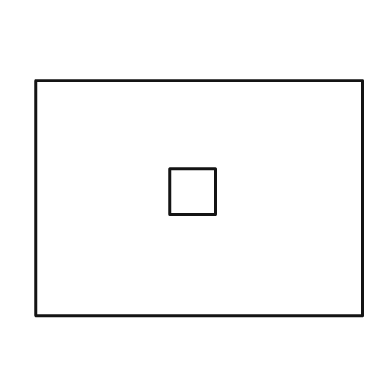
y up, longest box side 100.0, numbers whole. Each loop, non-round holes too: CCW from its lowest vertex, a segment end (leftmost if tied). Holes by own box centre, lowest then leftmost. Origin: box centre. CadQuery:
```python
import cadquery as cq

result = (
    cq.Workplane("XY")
    .moveTo(-50.0, -36.0)
    .lineTo(50.0, -36.0)
    .lineTo(50.0, 36.0)
    .lineTo(-50.0, 36.0)
    .close()
    .moveTo(-9.0, -5.0)
    .lineTo(5.0, -5.0)
    .lineTo(5.0, 9.0)
    .lineTo(-9.0, 9.0)
    .close()
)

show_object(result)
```